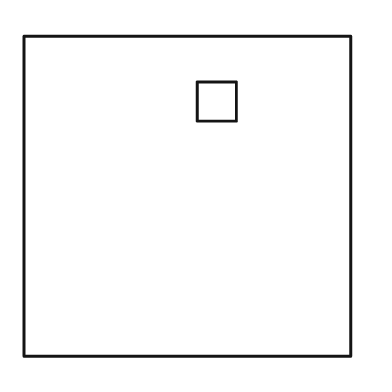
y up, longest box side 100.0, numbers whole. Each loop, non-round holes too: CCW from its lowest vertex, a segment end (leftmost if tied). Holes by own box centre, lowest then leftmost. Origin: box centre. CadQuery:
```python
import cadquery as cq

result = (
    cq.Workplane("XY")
    .moveTo(-50.0, -49.0)
    .lineTo(50.0, -49.0)
    .lineTo(50.0, 49.0)
    .lineTo(-50.0, 49.0)
    .close()
    .moveTo(3.0, 23.0)
    .lineTo(15.0, 23.0)
    .lineTo(15.0, 35.0)
    .lineTo(3.0, 35.0)
    .close()
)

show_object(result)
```